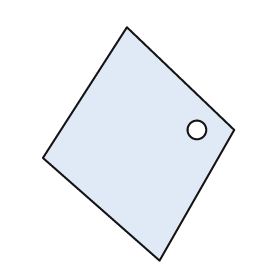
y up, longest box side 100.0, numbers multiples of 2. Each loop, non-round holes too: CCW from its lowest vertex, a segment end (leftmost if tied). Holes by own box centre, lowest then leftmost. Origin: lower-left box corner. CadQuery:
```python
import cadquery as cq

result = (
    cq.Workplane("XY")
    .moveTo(50.0, 0.0)
    .lineTo(82.0, 56.0)
    .lineTo(36.0, 100.0)
    .lineTo(0.0, 44.0)
    .close()
    .moveTo(66.0, 56.0)
    .circle(4.0)
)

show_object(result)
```